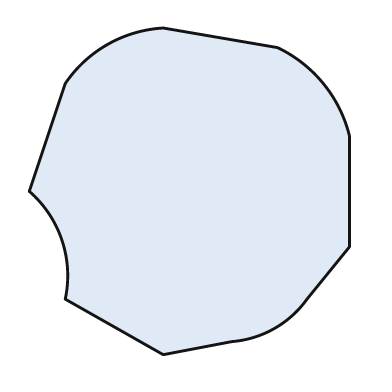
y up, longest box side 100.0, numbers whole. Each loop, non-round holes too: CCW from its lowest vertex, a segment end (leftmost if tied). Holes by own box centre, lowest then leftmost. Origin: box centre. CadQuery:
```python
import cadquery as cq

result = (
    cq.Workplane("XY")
    .moveTo(-8.0, -50.0)
    .lineTo(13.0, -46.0)
    .threePointArc((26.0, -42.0), (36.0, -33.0))
    .lineTo(49.0, -17.0)
    .lineTo(49.0, 17.0)
    .threePointArc((41.0, 33.0), (27.0, 44.0))
    .lineTo(-8.0, 50.0)
    .threePointArc((-25.0, 45.0), (-38.0, 33.0))
    .lineTo(-49.0, 0.0)
    .threePointArc((-39.0, -15.0), (-38.0, -33.0))
    .close()
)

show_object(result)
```